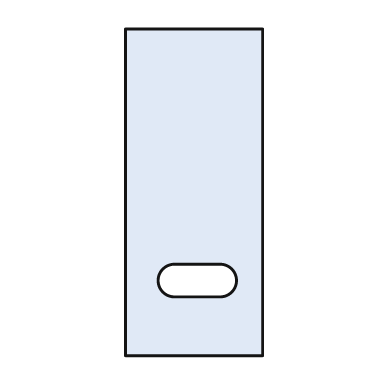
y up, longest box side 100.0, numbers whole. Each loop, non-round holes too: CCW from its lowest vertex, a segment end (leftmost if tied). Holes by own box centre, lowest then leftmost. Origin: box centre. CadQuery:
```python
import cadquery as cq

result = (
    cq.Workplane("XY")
    .moveTo(-21.0, -50.0)
    .lineTo(21.0, -50.0)
    .lineTo(21.0, 50.0)
    .lineTo(-21.0, 50.0)
    .close()
    .moveTo(-6.0, -32.0)
    .lineTo(8.0, -32.0)
    .threePointArc((13.0, -27.0), (8.0, -22.0))
    .lineTo(-6.0, -22.0)
    .threePointArc((-11.0, -27.0), (-6.0, -32.0))
    .close()
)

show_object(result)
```